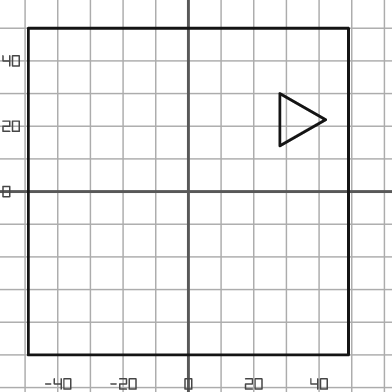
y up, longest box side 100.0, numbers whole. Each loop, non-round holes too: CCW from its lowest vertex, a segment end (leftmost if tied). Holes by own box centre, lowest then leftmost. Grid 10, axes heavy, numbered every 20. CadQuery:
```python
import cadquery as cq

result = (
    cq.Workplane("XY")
    .moveTo(-49.0, -50.0)
    .lineTo(49.0, -50.0)
    .lineTo(49.0, 50.0)
    .lineTo(-49.0, 50.0)
    .close()
    .moveTo(28.0, 14.0)
    .lineTo(42.0, 22.0)
    .lineTo(28.0, 30.0)
    .close()
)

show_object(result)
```